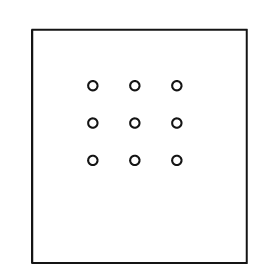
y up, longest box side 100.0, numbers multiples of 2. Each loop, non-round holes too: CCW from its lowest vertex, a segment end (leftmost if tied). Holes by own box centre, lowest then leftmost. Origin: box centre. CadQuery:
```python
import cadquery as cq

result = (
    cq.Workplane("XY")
    .moveTo(-46.0, -50.0)
    .lineTo(46.0, -50.0)
    .lineTo(46.0, 50.0)
    .lineTo(-46.0, 50.0)
    .close()
    .moveTo(-20.0, -6.0)
    .circle(2.0)
    .moveTo(-2.0, -6.0)
    .circle(2.0)
    .moveTo(16.0, -6.0)
    .circle(2.0)
    .moveTo(-20.0, 10.0)
    .circle(2.0)
    .moveTo(-2.0, 10.0)
    .circle(2.0)
    .moveTo(16.0, 10.0)
    .circle(2.0)
    .moveTo(-20.0, 26.0)
    .circle(2.0)
    .moveTo(-2.0, 26.0)
    .circle(2.0)
    .moveTo(16.0, 26.0)
    .circle(2.0)
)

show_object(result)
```